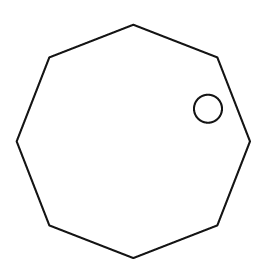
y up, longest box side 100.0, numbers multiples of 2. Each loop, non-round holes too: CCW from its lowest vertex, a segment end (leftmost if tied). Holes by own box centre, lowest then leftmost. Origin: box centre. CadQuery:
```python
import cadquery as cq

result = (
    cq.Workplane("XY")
    .moveTo(0.0, -50.0)
    .lineTo(36.0, -36.0)
    .lineTo(50.0, 0.0)
    .lineTo(36.0, 36.0)
    .lineTo(0.0, 50.0)
    .lineTo(-36.0, 36.0)
    .lineTo(-50.0, 0.0)
    .lineTo(-36.0, -36.0)
    .close()
    .moveTo(32.0, 14.0)
    .circle(6.0)
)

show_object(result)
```